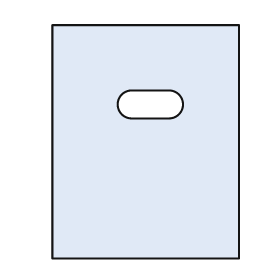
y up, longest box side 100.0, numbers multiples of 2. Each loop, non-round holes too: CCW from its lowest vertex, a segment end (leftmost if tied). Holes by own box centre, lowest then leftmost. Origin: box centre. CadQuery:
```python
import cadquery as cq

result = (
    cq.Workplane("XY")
    .moveTo(-40.0, -50.0)
    .lineTo(40.0, -50.0)
    .lineTo(40.0, 50.0)
    .lineTo(-40.0, 50.0)
    .close()
    .moveTo(-6.0, 10.0)
    .lineTo(10.0, 10.0)
    .threePointArc((16.0, 16.0), (10.0, 22.0))
    .lineTo(-6.0, 22.0)
    .threePointArc((-12.0, 16.0), (-6.0, 10.0))
    .close()
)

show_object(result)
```